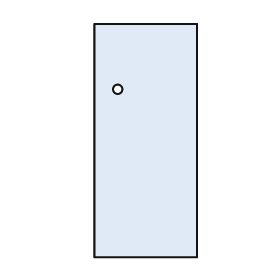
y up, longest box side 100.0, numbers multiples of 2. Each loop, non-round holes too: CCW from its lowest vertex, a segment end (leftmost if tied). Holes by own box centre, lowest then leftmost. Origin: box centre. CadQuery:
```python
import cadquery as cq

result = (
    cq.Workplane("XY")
    .moveTo(-22.0, -50.0)
    .lineTo(22.0, -50.0)
    .lineTo(22.0, 50.0)
    .lineTo(-22.0, 50.0)
    .close()
    .moveTo(-12.0, 22.0)
    .circle(2.0)
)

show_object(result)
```